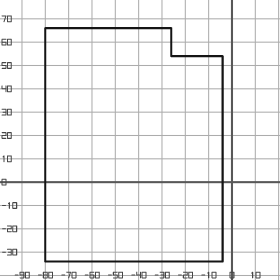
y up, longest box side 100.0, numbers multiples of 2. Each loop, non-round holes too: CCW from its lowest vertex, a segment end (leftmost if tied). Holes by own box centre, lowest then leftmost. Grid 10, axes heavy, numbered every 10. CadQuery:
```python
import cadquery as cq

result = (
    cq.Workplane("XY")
    .moveTo(-80.0, -34.0)
    .lineTo(-4.0, -34.0)
    .lineTo(-4.0, 54.0)
    .lineTo(-26.0, 54.0)
    .lineTo(-26.0, 66.0)
    .lineTo(-80.0, 66.0)
    .close()
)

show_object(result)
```